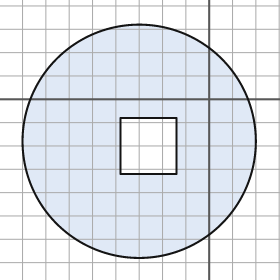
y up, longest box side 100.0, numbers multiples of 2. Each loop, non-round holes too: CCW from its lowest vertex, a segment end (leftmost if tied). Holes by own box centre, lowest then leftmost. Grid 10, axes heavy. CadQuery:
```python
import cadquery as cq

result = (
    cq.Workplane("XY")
    .moveTo(-30.0, -18.0)
    .circle(50.0)
    .moveTo(-38.0, -32.0)
    .lineTo(-14.0, -32.0)
    .lineTo(-14.0, -8.0)
    .lineTo(-38.0, -8.0)
    .close()
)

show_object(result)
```